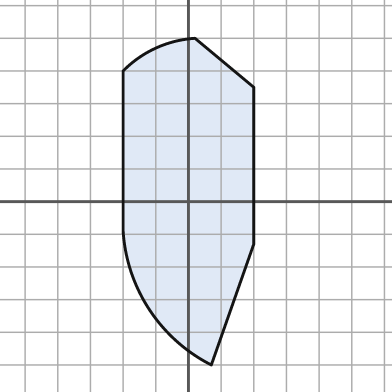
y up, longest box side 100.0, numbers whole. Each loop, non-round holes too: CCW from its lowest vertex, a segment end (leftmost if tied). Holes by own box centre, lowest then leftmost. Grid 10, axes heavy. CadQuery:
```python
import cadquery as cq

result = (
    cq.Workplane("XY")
    .moveTo(7.0, -50.0)
    .lineTo(20.0, -13.0)
    .lineTo(20.0, 35.0)
    .lineTo(2.0, 50.0)
    .threePointArc((-10.0, 47.0), (-20.0, 40.0))
    .lineTo(-20.0, -9.0)
    .threePointArc((-12.0, -33.0), (7.0, -50.0))
    .close()
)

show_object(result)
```